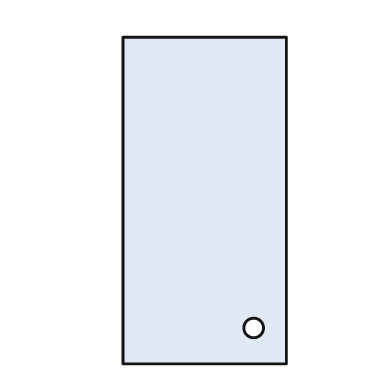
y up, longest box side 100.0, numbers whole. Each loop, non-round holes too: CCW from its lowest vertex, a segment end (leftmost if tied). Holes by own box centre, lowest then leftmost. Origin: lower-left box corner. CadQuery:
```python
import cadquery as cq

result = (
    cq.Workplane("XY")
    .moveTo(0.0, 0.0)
    .lineTo(50.0, 0.0)
    .lineTo(50.0, 100.0)
    .lineTo(0.0, 100.0)
    .close()
    .moveTo(40.0, 11.0)
    .circle(3.0)
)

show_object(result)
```